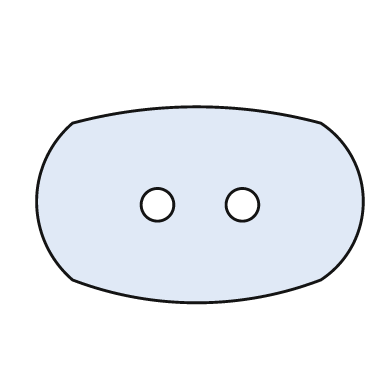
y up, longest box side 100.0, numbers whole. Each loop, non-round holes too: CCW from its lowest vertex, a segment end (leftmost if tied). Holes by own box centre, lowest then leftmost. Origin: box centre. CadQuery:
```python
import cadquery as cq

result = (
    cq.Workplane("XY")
    .moveTo(-39.0, -23.0)
    .threePointArc((-1.0, -30.0), (37.0, -23.0))
    .threePointArc((50.0, 1.0), (37.0, 25.0))
    .threePointArc((-1.0, 30.0), (-39.0, 25.0))
    .threePointArc((-50.0, 1.0), (-39.0, -23.0))
    .close()
    .moveTo(-13.0, 0.0)
    .circle(5.0)
    .moveTo(13.0, 0.0)
    .circle(5.0)
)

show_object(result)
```